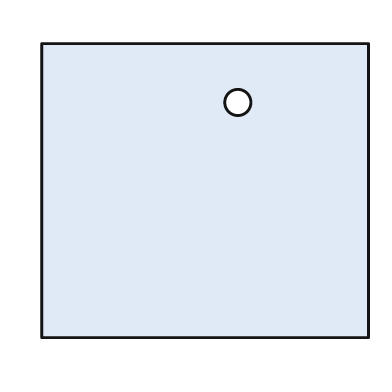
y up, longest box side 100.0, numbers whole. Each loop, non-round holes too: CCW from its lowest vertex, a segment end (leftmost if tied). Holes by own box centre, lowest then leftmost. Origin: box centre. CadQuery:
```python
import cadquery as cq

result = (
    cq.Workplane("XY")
    .moveTo(-50.0, -45.0)
    .lineTo(50.0, -45.0)
    .lineTo(50.0, 45.0)
    .lineTo(-50.0, 45.0)
    .close()
    .moveTo(10.0, 27.0)
    .circle(4.0)
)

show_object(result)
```